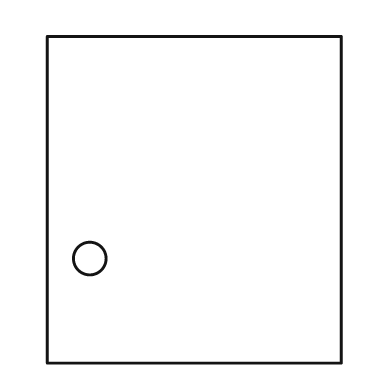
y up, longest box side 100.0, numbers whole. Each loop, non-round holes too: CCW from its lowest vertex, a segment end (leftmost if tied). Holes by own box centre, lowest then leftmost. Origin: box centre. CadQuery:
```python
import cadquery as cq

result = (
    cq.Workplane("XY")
    .moveTo(-45.0, -50.0)
    .lineTo(45.0, -50.0)
    .lineTo(45.0, 50.0)
    .lineTo(-45.0, 50.0)
    .close()
    .moveTo(-32.0, -18.0)
    .circle(5.0)
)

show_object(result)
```